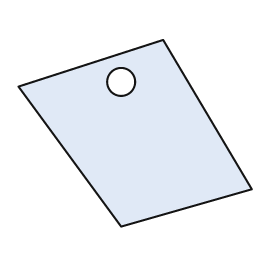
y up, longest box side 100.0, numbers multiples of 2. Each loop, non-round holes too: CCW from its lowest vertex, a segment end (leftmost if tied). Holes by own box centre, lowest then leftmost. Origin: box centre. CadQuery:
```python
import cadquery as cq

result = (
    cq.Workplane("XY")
    .moveTo(-6.0, -40.0)
    .lineTo(50.0, -24.0)
    .lineTo(12.0, 40.0)
    .lineTo(-50.0, 20.0)
    .close()
    .moveTo(-6.0, 22.0)
    .circle(6.0)
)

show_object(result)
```